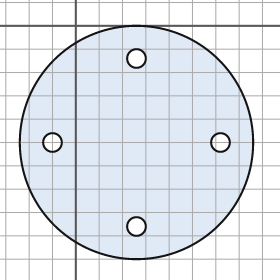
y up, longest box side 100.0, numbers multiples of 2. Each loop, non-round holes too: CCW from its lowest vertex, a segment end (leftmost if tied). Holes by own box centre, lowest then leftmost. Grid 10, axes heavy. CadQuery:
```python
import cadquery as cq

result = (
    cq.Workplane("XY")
    .moveTo(26.0, -50.0)
    .circle(50.0)
    .moveTo(26.0, -86.0)
    .circle(4.0)
    .moveTo(-10.0, -50.0)
    .circle(4.0)
    .moveTo(62.0, -50.0)
    .circle(4.0)
    .moveTo(26.0, -14.0)
    .circle(4.0)
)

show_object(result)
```